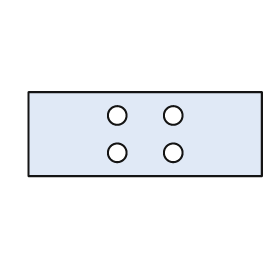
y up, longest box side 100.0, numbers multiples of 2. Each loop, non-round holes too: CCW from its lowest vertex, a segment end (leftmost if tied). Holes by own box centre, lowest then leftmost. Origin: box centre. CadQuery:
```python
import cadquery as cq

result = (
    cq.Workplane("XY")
    .moveTo(-50.0, -18.0)
    .lineTo(50.0, -18.0)
    .lineTo(50.0, 18.0)
    .lineTo(-50.0, 18.0)
    .close()
    .moveTo(-12.0, -8.0)
    .circle(4.0)
    .moveTo(12.0, -8.0)
    .circle(4.0)
    .moveTo(-12.0, 8.0)
    .circle(4.0)
    .moveTo(12.0, 8.0)
    .circle(4.0)
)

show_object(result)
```